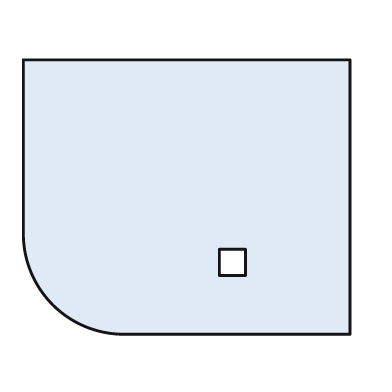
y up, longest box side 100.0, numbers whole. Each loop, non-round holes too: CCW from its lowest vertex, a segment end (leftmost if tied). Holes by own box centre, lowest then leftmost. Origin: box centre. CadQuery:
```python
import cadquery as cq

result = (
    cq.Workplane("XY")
    .moveTo(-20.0, -42.0)
    .lineTo(50.0, -42.0)
    .lineTo(50.0, 42.0)
    .lineTo(-50.0, 42.0)
    .lineTo(-50.0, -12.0)
    .threePointArc((-41.0, -33.0), (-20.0, -42.0))
    .close()
    .moveTo(10.0, -24.0)
    .lineTo(18.0, -24.0)
    .lineTo(18.0, -16.0)
    .lineTo(10.0, -16.0)
    .close()
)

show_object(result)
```